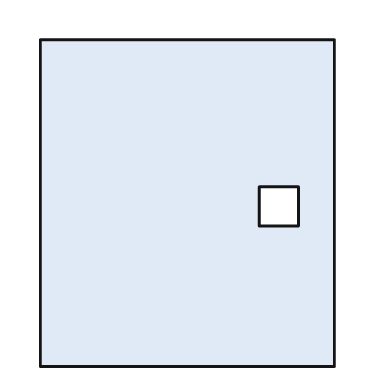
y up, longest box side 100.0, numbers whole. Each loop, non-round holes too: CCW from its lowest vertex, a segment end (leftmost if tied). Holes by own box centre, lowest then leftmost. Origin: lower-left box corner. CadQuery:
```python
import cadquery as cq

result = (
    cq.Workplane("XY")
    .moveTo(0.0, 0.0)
    .lineTo(90.0, 0.0)
    .lineTo(90.0, 100.0)
    .lineTo(0.0, 100.0)
    .close()
    .moveTo(67.0, 43.0)
    .lineTo(79.0, 43.0)
    .lineTo(79.0, 55.0)
    .lineTo(67.0, 55.0)
    .close()
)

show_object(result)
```